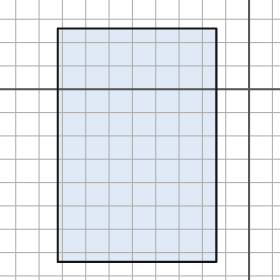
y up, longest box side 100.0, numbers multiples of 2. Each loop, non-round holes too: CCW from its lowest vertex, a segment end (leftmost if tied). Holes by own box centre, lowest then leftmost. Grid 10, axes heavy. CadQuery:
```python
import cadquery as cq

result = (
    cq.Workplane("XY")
    .moveTo(-82.0, -74.0)
    .lineTo(-14.0, -74.0)
    .lineTo(-14.0, 26.0)
    .lineTo(-82.0, 26.0)
    .close()
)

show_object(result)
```